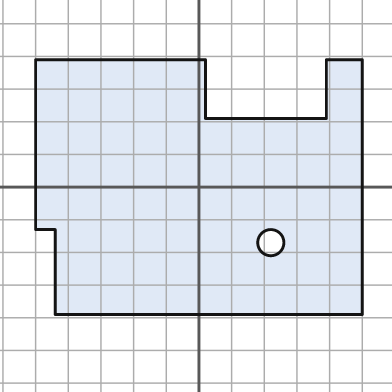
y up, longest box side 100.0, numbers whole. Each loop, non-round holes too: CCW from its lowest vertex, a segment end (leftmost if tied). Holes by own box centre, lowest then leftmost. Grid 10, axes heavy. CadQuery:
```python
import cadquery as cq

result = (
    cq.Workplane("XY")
    .moveTo(-44.0, -39.0)
    .lineTo(50.0, -39.0)
    .lineTo(50.0, 39.0)
    .lineTo(39.0, 39.0)
    .lineTo(39.0, 21.0)
    .lineTo(2.0, 21.0)
    .lineTo(2.0, 39.0)
    .lineTo(-50.0, 39.0)
    .lineTo(-50.0, -13.0)
    .lineTo(-44.0, -13.0)
    .close()
    .moveTo(22.0, -17.0)
    .circle(4.0)
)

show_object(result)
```